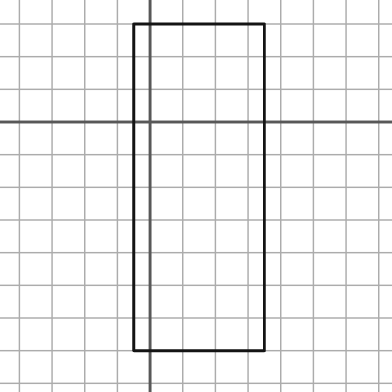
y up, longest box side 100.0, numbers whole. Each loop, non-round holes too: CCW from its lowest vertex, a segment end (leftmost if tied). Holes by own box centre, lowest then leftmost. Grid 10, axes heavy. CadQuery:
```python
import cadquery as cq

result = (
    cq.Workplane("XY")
    .moveTo(-5.0, -70.0)
    .lineTo(35.0, -70.0)
    .lineTo(35.0, 30.0)
    .lineTo(-5.0, 30.0)
    .close()
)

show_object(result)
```